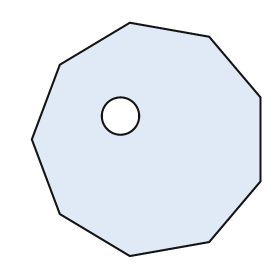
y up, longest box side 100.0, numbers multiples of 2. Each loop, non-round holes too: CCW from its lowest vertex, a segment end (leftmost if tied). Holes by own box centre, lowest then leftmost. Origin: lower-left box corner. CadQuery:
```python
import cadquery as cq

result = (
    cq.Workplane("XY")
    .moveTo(42.0, 0.0)
    .lineTo(76.0, 6.0)
    .lineTo(98.0, 32.0)
    .lineTo(98.0, 68.0)
    .lineTo(76.0, 94.0)
    .lineTo(42.0, 100.0)
    .lineTo(12.0, 82.0)
    .lineTo(0.0, 50.0)
    .lineTo(12.0, 18.0)
    .close()
    .moveTo(38.0, 60.0)
    .circle(8.0)
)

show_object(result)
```